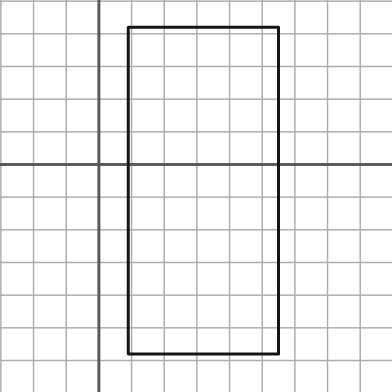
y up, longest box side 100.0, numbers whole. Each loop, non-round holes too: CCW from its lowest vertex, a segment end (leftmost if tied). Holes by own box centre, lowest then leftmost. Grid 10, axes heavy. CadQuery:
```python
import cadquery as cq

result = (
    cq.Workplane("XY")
    .moveTo(9.0, -58.0)
    .lineTo(55.0, -58.0)
    .lineTo(55.0, 42.0)
    .lineTo(9.0, 42.0)
    .close()
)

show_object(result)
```